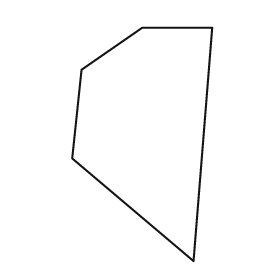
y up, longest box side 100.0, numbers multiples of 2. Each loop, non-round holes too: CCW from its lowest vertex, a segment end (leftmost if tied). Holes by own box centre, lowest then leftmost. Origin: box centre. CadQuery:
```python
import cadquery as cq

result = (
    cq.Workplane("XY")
    .moveTo(22.0, -50.0)
    .lineTo(30.0, 50.0)
    .lineTo(0.0, 50.0)
    .lineTo(-26.0, 32.0)
    .lineTo(-30.0, -6.0)
    .close()
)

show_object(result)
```